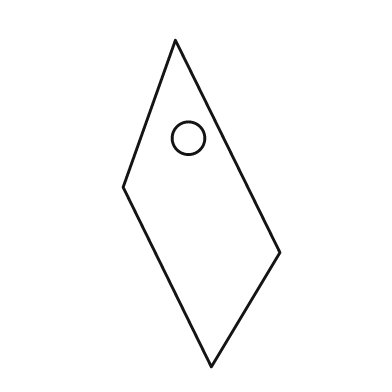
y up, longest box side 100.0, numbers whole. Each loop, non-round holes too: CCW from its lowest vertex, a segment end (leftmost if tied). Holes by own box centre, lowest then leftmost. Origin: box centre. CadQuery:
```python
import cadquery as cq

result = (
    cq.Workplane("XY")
    .moveTo(3.0, -50.0)
    .lineTo(24.0, -15.0)
    .lineTo(-8.0, 50.0)
    .lineTo(-24.0, 5.0)
    .close()
    .moveTo(-4.0, 20.0)
    .circle(5.0)
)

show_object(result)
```